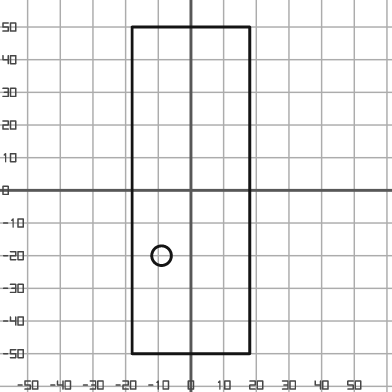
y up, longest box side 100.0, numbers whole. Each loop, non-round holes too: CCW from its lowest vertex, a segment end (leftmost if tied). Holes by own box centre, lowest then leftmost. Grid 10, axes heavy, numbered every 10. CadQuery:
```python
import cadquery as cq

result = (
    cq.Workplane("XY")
    .moveTo(-18.0, -50.0)
    .lineTo(18.0, -50.0)
    .lineTo(18.0, 50.0)
    .lineTo(-18.0, 50.0)
    .close()
    .moveTo(-9.0, -20.0)
    .circle(3.0)
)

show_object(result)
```